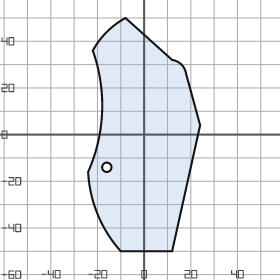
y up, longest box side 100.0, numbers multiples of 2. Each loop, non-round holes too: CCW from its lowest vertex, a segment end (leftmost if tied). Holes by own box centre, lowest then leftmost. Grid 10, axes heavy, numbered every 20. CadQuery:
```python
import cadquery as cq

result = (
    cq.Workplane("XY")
    .moveTo(-10.0, -50.0)
    .lineTo(12.0, -50.0)
    .lineTo(24.0, 4.0)
    .lineTo(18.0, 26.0)
    .threePointArc((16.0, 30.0), (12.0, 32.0))
    .lineTo(-8.0, 50.0)
    .threePointArc((-16.0, 44.0), (-22.0, 36.0))
    .threePointArc((-18.0, 10.0), (-24.0, -16.0))
    .threePointArc((-20.0, -34.0), (-10.0, -50.0))
    .close()
    .moveTo(-16.0, -14.0)
    .circle(2.0)
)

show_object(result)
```